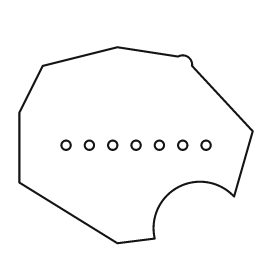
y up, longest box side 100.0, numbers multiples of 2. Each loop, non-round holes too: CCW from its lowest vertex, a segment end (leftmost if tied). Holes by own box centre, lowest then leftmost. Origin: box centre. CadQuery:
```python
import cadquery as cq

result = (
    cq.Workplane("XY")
    .moveTo(-8.0, -42.0)
    .lineTo(8.0, -40.0)
    .threePointArc((18.0, -18.0), (42.0, -22.0))
    .lineTo(50.0, 6.0)
    .lineTo(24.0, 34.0)
    .threePointArc((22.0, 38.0), (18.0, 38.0))
    .lineTo(-8.0, 42.0)
    .lineTo(-40.0, 34.0)
    .lineTo(-50.0, 14.0)
    .lineTo(-50.0, -16.0)
    .close()
    .moveTo(-30.0, 0.0)
    .circle(2.0)
    .moveTo(-20.0, 0.0)
    .circle(2.0)
    .moveTo(-10.0, 0.0)
    .circle(2.0)
    .moveTo(0.0, 0.0)
    .circle(2.0)
    .moveTo(10.0, 0.0)
    .circle(2.0)
    .moveTo(20.0, 0.0)
    .circle(2.0)
    .moveTo(30.0, 0.0)
    .circle(2.0)
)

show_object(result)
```